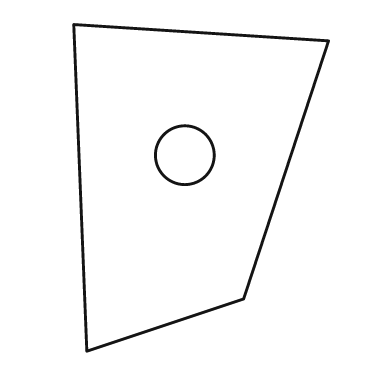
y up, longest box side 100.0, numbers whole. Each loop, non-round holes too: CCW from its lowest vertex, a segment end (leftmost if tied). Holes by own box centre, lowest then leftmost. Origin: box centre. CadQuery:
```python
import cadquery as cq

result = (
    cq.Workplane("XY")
    .moveTo(-35.0, -50.0)
    .lineTo(13.0, -34.0)
    .lineTo(39.0, 45.0)
    .lineTo(-39.0, 50.0)
    .close()
    .moveTo(-5.0, 10.0)
    .circle(9.0)
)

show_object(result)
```